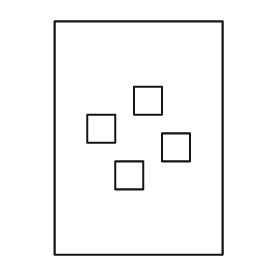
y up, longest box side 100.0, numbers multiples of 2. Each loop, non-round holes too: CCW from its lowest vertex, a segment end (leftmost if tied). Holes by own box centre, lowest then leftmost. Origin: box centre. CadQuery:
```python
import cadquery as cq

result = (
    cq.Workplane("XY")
    .moveTo(-36.0, -50.0)
    .lineTo(36.0, -50.0)
    .lineTo(36.0, 50.0)
    .lineTo(-36.0, 50.0)
    .close()
    .moveTo(-10.0, -22.0)
    .lineTo(2.0, -22.0)
    .lineTo(2.0, -10.0)
    .lineTo(-10.0, -10.0)
    .close()
    .moveTo(10.0, -10.0)
    .lineTo(22.0, -10.0)
    .lineTo(22.0, 2.0)
    .lineTo(10.0, 2.0)
    .close()
    .moveTo(-22.0, -2.0)
    .lineTo(-10.0, -2.0)
    .lineTo(-10.0, 10.0)
    .lineTo(-22.0, 10.0)
    .close()
    .moveTo(-2.0, 10.0)
    .lineTo(10.0, 10.0)
    .lineTo(10.0, 22.0)
    .lineTo(-2.0, 22.0)
    .close()
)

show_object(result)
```